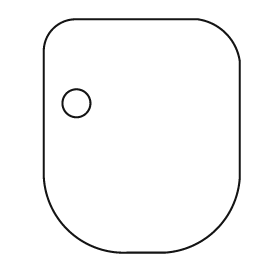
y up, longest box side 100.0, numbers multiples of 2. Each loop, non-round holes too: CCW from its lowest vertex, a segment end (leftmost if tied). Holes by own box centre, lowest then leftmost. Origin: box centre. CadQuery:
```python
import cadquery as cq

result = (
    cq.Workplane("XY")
    .moveTo(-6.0, -50.0)
    .lineTo(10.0, -50.0)
    .threePointArc((32.0, -40.0), (42.0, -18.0))
    .lineTo(42.0, 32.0)
    .threePointArc((36.0, 44.0), (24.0, 50.0))
    .lineTo(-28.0, 50.0)
    .threePointArc((-38.0, 46.0), (-42.0, 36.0))
    .lineTo(-42.0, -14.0)
    .threePointArc((-32.0, -40.0), (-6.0, -50.0))
    .close()
    .moveTo(-28.0, 14.0)
    .circle(6.0)
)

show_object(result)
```